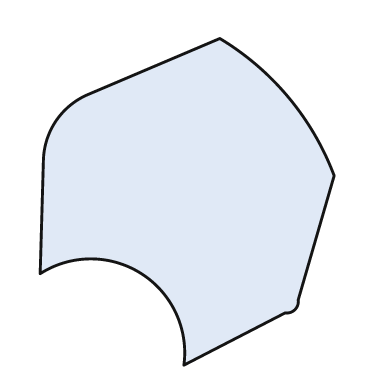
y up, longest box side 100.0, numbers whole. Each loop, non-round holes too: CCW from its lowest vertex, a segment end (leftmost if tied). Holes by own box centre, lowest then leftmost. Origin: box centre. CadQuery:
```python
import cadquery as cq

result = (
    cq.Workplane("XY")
    .moveTo(-1.0, -50.0)
    .lineTo(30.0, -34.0)
    .threePointArc((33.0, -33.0), (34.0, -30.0))
    .lineTo(45.0, 8.0)
    .threePointArc((31.0, 32.0), (10.0, 50.0))
    .lineTo(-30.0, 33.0)
    .threePointArc((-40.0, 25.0), (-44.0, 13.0))
    .lineTo(-45.0, -22.0)
    .threePointArc((-14.0, -22.0), (-1.0, -50.0))
    .close()
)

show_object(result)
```